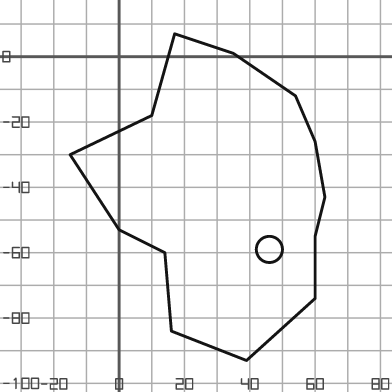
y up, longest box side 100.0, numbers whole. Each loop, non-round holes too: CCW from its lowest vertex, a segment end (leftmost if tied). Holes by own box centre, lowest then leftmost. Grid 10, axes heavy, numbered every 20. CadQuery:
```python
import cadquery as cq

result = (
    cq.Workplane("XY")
    .moveTo(39.0, -93.0)
    .lineTo(60.0, -74.0)
    .lineTo(60.0, -55.0)
    .lineTo(63.0, -43.0)
    .lineTo(60.0, -26.0)
    .lineTo(54.0, -12.0)
    .lineTo(35.0, 1.0)
    .lineTo(17.0, 7.0)
    .lineTo(10.0, -18.0)
    .lineTo(-15.0, -30.0)
    .lineTo(0.0, -53.0)
    .lineTo(14.0, -60.0)
    .lineTo(16.0, -84.0)
    .close()
    .moveTo(46.0, -59.0)
    .circle(4.0)
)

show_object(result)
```